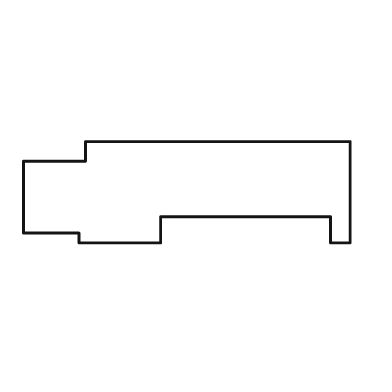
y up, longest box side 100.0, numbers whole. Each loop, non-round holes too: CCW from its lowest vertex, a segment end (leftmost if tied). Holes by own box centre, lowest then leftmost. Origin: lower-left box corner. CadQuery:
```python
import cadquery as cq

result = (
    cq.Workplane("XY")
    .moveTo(17.0, 0.0)
    .lineTo(42.0, 0.0)
    .lineTo(42.0, 8.0)
    .lineTo(94.0, 8.0)
    .lineTo(94.0, 0.0)
    .lineTo(100.0, 0.0)
    .lineTo(100.0, 31.0)
    .lineTo(19.0, 31.0)
    .lineTo(19.0, 25.0)
    .lineTo(0.0, 25.0)
    .lineTo(0.0, 3.0)
    .lineTo(17.0, 3.0)
    .close()
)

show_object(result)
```